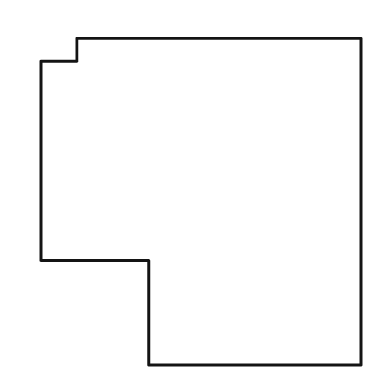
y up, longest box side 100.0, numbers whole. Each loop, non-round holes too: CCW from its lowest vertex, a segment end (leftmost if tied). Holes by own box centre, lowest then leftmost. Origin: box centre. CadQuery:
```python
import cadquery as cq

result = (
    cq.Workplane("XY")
    .moveTo(-16.0, -50.0)
    .lineTo(49.0, -50.0)
    .lineTo(49.0, 50.0)
    .lineTo(-38.0, 50.0)
    .lineTo(-38.0, 43.0)
    .lineTo(-49.0, 43.0)
    .lineTo(-49.0, -18.0)
    .lineTo(-16.0, -18.0)
    .close()
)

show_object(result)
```